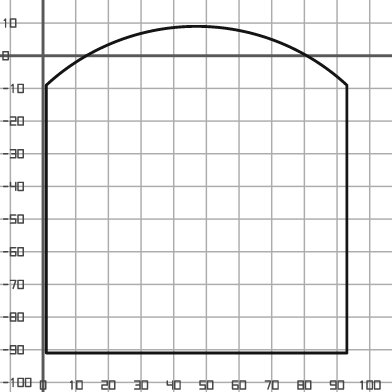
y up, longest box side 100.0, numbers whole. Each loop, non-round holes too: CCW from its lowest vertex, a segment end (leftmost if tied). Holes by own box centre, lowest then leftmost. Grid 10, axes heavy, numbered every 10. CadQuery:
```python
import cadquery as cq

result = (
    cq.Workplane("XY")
    .moveTo(1.0, -91.0)
    .lineTo(93.0, -91.0)
    .lineTo(93.0, -9.0)
    .threePointArc((47.0, 9.0), (1.0, -9.0))
    .close()
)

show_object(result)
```